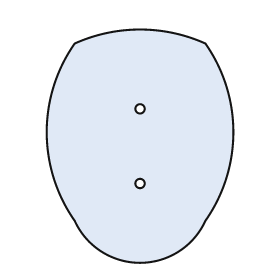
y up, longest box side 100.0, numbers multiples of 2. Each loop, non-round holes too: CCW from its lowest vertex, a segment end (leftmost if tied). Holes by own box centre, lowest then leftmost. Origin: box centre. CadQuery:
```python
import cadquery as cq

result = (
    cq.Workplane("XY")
    .moveTo(-28.0, -32.0)
    .threePointArc((0.0, -50.0), (28.0, -32.0))
    .threePointArc((40.0, 6.0), (28.0, 44.0))
    .threePointArc((0.0, 50.0), (-28.0, 44.0))
    .threePointArc((-40.0, 6.0), (-28.0, -32.0))
    .close()
    .moveTo(0.0, -16.0)
    .circle(2.0)
    .moveTo(0.0, 16.0)
    .circle(2.0)
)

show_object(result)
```